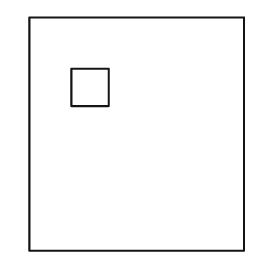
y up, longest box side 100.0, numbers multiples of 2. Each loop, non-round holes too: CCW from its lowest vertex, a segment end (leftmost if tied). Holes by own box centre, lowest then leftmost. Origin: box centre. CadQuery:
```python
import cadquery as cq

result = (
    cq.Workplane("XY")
    .moveTo(-46.0, -50.0)
    .lineTo(46.0, -50.0)
    .lineTo(46.0, 50.0)
    .lineTo(-46.0, 50.0)
    .close()
    .moveTo(-28.0, 12.0)
    .lineTo(-12.0, 12.0)
    .lineTo(-12.0, 28.0)
    .lineTo(-28.0, 28.0)
    .close()
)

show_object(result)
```